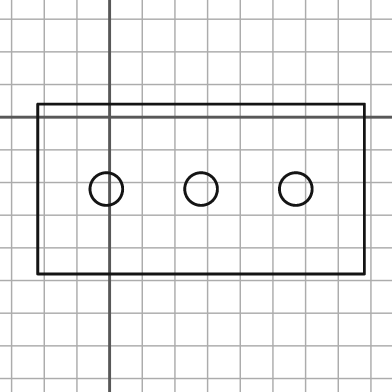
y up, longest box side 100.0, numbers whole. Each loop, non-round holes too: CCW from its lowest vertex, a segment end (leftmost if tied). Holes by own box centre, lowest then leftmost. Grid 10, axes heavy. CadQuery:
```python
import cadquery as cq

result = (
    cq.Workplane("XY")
    .moveTo(-22.0, -48.0)
    .lineTo(78.0, -48.0)
    .lineTo(78.0, 4.0)
    .lineTo(-22.0, 4.0)
    .close()
    .moveTo(-1.0, -22.0)
    .circle(5.0)
    .moveTo(28.0, -22.0)
    .circle(5.0)
    .moveTo(57.0, -22.0)
    .circle(5.0)
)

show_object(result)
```